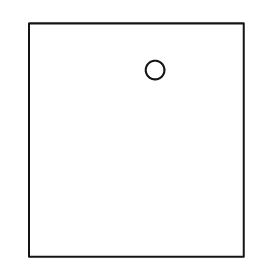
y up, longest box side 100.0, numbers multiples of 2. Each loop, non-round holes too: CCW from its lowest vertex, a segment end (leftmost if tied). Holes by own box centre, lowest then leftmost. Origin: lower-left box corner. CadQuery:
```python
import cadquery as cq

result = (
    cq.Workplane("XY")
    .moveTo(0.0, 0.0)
    .lineTo(92.0, 0.0)
    .lineTo(92.0, 100.0)
    .lineTo(0.0, 100.0)
    .close()
    .moveTo(54.0, 80.0)
    .circle(4.0)
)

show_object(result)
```